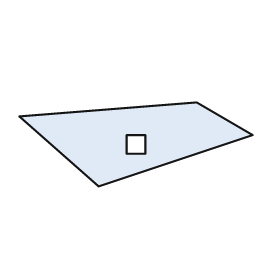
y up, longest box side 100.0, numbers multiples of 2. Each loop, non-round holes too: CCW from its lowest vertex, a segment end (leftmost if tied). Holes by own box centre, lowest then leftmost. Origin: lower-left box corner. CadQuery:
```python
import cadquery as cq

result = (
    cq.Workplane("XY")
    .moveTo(34.0, 0.0)
    .lineTo(100.0, 22.0)
    .lineTo(76.0, 36.0)
    .lineTo(0.0, 30.0)
    .close()
    .moveTo(46.0, 14.0)
    .lineTo(54.0, 14.0)
    .lineTo(54.0, 22.0)
    .lineTo(46.0, 22.0)
    .close()
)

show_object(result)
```